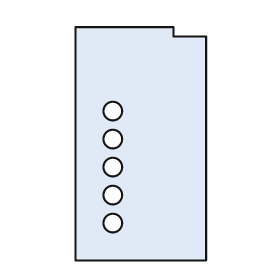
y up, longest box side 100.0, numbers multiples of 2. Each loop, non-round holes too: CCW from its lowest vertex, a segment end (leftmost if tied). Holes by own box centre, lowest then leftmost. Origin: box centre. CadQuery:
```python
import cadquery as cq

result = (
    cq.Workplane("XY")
    .moveTo(-28.0, -50.0)
    .lineTo(28.0, -50.0)
    .lineTo(28.0, 46.0)
    .lineTo(14.0, 46.0)
    .lineTo(14.0, 50.0)
    .lineTo(-28.0, 50.0)
    .close()
    .moveTo(-12.0, -34.0)
    .circle(4.0)
    .moveTo(-12.0, -22.0)
    .circle(4.0)
    .moveTo(-12.0, -10.0)
    .circle(4.0)
    .moveTo(-12.0, 2.0)
    .circle(4.0)
    .moveTo(-12.0, 14.0)
    .circle(4.0)
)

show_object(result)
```